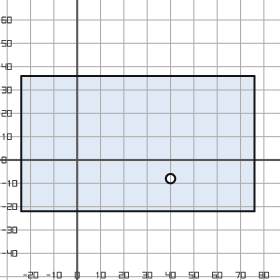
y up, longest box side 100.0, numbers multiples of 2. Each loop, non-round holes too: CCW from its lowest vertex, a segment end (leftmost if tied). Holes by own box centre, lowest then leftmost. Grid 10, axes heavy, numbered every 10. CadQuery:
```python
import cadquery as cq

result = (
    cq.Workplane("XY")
    .moveTo(-24.0, -22.0)
    .lineTo(76.0, -22.0)
    .lineTo(76.0, 36.0)
    .lineTo(-24.0, 36.0)
    .close()
    .moveTo(40.0, -8.0)
    .circle(2.0)
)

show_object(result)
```